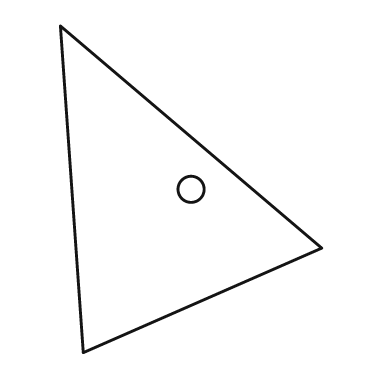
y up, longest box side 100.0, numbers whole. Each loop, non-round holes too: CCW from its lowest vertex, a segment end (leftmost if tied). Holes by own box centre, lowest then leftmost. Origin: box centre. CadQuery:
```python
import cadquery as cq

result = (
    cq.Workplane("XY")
    .moveTo(-33.0, -50.0)
    .lineTo(40.0, -18.0)
    .lineTo(-40.0, 50.0)
    .close()
    .moveTo(0.0, 0.0)
    .circle(4.0)
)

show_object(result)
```